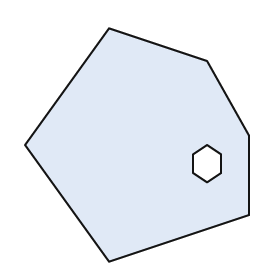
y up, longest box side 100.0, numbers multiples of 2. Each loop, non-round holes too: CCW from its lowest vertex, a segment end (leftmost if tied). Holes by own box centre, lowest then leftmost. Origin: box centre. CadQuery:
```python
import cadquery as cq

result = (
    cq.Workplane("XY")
    .moveTo(-12.0, -50.0)
    .lineTo(48.0, -30.0)
    .lineTo(48.0, 4.0)
    .lineTo(30.0, 36.0)
    .lineTo(-12.0, 50.0)
    .lineTo(-48.0, 0.0)
    .close()
    .moveTo(30.0, -16.0)
    .lineTo(36.0, -12.0)
    .lineTo(36.0, -4.0)
    .lineTo(30.0, 0.0)
    .lineTo(24.0, -4.0)
    .lineTo(24.0, -12.0)
    .close()
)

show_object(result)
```